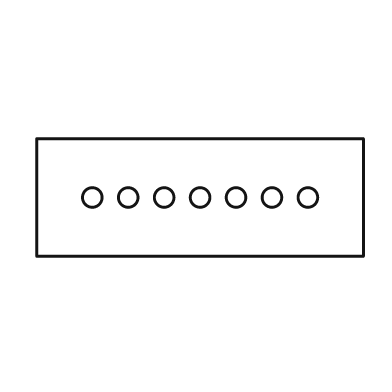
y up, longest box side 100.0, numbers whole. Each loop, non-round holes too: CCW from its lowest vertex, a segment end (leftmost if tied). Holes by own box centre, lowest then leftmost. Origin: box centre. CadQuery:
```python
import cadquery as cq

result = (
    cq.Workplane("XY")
    .moveTo(-50.0, -18.0)
    .lineTo(50.0, -18.0)
    .lineTo(50.0, 18.0)
    .lineTo(-50.0, 18.0)
    .close()
    .moveTo(-33.0, 0.0)
    .circle(3.0)
    .moveTo(-22.0, 0.0)
    .circle(3.0)
    .moveTo(-11.0, 0.0)
    .circle(3.0)
    .moveTo(0.0, 0.0)
    .circle(3.0)
    .moveTo(11.0, 0.0)
    .circle(3.0)
    .moveTo(22.0, 0.0)
    .circle(3.0)
    .moveTo(33.0, 0.0)
    .circle(3.0)
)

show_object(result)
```